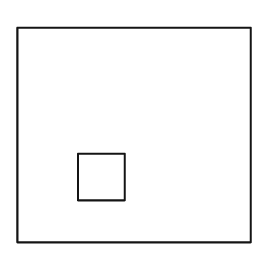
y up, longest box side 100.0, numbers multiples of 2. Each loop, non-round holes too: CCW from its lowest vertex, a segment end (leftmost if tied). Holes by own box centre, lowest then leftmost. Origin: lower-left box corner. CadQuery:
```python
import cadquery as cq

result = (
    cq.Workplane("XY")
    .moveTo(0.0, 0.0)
    .lineTo(100.0, 0.0)
    .lineTo(100.0, 92.0)
    .lineTo(0.0, 92.0)
    .close()
    .moveTo(26.0, 18.0)
    .lineTo(46.0, 18.0)
    .lineTo(46.0, 38.0)
    .lineTo(26.0, 38.0)
    .close()
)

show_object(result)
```